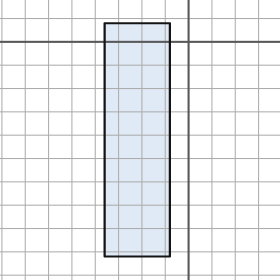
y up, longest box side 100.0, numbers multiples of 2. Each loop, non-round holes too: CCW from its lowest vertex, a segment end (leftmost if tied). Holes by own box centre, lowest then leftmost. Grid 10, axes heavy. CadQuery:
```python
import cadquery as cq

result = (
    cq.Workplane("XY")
    .moveTo(-36.0, -92.0)
    .lineTo(-8.0, -92.0)
    .lineTo(-8.0, 8.0)
    .lineTo(-36.0, 8.0)
    .close()
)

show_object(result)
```